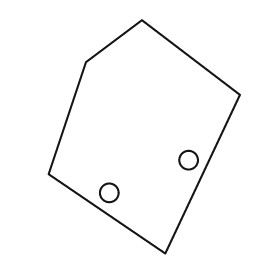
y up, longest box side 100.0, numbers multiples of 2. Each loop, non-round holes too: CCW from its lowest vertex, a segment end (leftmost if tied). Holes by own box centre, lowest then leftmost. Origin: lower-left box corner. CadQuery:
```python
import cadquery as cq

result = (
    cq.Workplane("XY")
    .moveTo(50.0, 0.0)
    .lineTo(82.0, 68.0)
    .lineTo(40.0, 100.0)
    .lineTo(16.0, 82.0)
    .lineTo(0.0, 34.0)
    .close()
    .moveTo(26.0, 26.0)
    .circle(4.0)
    .moveTo(60.0, 40.0)
    .circle(4.0)
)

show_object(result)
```